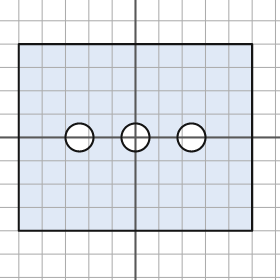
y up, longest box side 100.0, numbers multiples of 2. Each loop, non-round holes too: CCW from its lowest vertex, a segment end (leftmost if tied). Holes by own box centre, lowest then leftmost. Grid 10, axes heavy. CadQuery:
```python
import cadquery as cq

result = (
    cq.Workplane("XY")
    .moveTo(-50.0, -40.0)
    .lineTo(50.0, -40.0)
    .lineTo(50.0, 40.0)
    .lineTo(-50.0, 40.0)
    .close()
    .moveTo(-24.0, 0.0)
    .circle(6.0)
    .moveTo(0.0, 0.0)
    .circle(6.0)
    .moveTo(24.0, 0.0)
    .circle(6.0)
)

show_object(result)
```